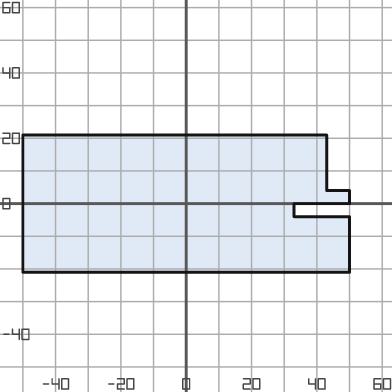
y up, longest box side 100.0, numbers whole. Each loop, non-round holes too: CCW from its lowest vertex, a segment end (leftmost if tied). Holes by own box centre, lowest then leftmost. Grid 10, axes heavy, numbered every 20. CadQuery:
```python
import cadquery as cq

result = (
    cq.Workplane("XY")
    .moveTo(-50.0, -21.0)
    .lineTo(50.0, -21.0)
    .lineTo(50.0, -4.0)
    .lineTo(33.0, -4.0)
    .lineTo(33.0, 0.0)
    .lineTo(50.0, 0.0)
    .lineTo(50.0, 4.0)
    .lineTo(43.0, 4.0)
    .lineTo(43.0, 21.0)
    .lineTo(-50.0, 21.0)
    .close()
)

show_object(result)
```